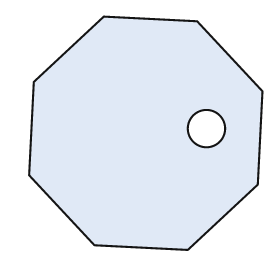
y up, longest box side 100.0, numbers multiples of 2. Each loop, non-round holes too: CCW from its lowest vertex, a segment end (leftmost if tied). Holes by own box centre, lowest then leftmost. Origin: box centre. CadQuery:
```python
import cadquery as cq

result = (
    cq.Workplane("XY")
    .moveTo(18.0, -50.0)
    .lineTo(48.0, -22.0)
    .lineTo(50.0, 18.0)
    .lineTo(22.0, 48.0)
    .lineTo(-18.0, 50.0)
    .lineTo(-48.0, 22.0)
    .lineTo(-50.0, -18.0)
    .lineTo(-22.0, -48.0)
    .close()
    .moveTo(26.0, 2.0)
    .circle(8.0)
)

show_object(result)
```